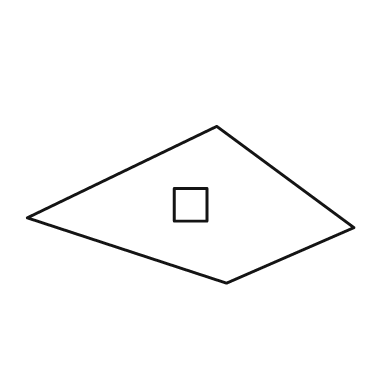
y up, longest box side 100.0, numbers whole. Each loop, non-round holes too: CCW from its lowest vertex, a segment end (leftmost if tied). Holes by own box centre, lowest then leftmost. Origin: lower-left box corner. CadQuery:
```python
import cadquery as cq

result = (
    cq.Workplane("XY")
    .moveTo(61.0, 0.0)
    .lineTo(100.0, 17.0)
    .lineTo(58.0, 48.0)
    .lineTo(0.0, 20.0)
    .close()
    .moveTo(45.0, 19.0)
    .lineTo(55.0, 19.0)
    .lineTo(55.0, 29.0)
    .lineTo(45.0, 29.0)
    .close()
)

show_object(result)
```